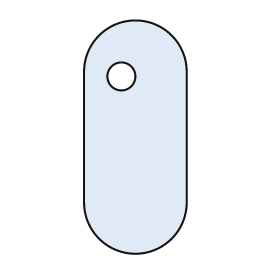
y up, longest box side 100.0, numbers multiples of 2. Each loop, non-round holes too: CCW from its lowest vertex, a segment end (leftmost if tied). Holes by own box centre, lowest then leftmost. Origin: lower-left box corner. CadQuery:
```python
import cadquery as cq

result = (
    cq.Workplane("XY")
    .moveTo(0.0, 22.0)
    .threePointArc((22.0, 0.0), (44.0, 22.0))
    .lineTo(44.0, 78.0)
    .threePointArc((22.0, 100.0), (0.0, 78.0))
    .close()
    .moveTo(16.0, 76.0)
    .circle(6.0)
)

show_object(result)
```